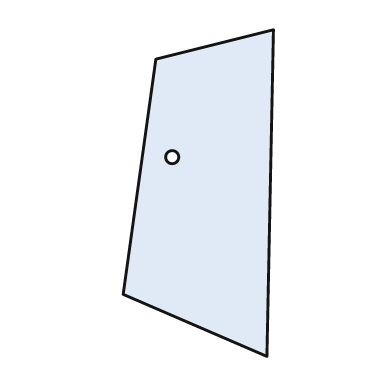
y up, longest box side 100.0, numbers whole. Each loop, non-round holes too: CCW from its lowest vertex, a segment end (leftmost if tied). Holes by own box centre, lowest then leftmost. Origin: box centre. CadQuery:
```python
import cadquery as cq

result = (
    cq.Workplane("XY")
    .moveTo(21.0, -50.0)
    .lineTo(23.0, 50.0)
    .lineTo(-13.0, 41.0)
    .lineTo(-23.0, -31.0)
    .close()
    .moveTo(-8.0, 11.0)
    .circle(2.0)
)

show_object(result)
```